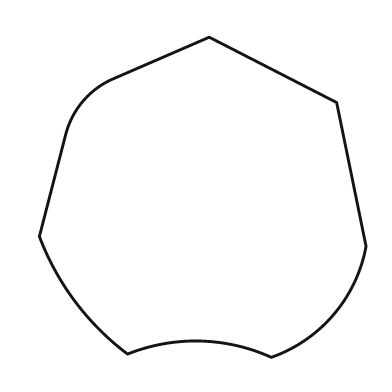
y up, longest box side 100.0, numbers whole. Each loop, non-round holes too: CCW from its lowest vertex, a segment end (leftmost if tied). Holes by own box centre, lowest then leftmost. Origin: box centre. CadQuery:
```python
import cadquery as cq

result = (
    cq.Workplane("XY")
    .moveTo(21.0, -49.0)
    .threePointArc((40.0, -36.0), (50.0, -15.0))
    .lineTo(41.0, 29.0)
    .lineTo(2.0, 49.0)
    .lineTo(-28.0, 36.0)
    .threePointArc((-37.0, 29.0), (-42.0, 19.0))
    .lineTo(-50.0, -12.0)
    .threePointArc((-39.0, -32.0), (-23.0, -48.0))
    .threePointArc((-1.0, -44.0), (21.0, -49.0))
    .close()
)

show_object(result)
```